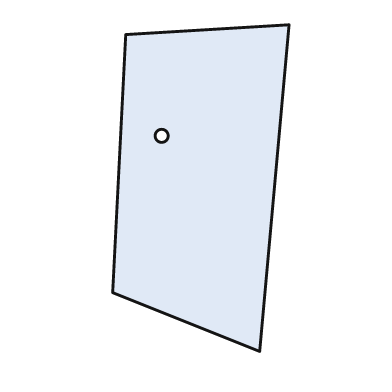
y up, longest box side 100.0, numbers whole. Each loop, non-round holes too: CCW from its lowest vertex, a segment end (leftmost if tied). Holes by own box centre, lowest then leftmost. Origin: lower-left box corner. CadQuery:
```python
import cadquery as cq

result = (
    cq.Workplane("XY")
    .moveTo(45.0, 0.0)
    .lineTo(54.0, 100.0)
    .lineTo(4.0, 97.0)
    .lineTo(0.0, 18.0)
    .close()
    .moveTo(15.0, 66.0)
    .circle(2.0)
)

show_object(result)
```